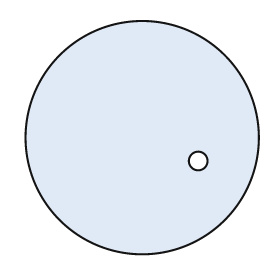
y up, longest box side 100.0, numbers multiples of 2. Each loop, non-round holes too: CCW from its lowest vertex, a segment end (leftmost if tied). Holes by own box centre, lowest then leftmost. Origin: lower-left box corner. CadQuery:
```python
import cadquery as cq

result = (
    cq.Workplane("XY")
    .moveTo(50.0, 50.0)
    .circle(50.0)
    .moveTo(74.0, 40.0)
    .circle(4.0)
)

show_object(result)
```